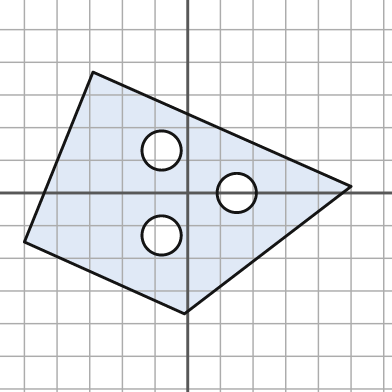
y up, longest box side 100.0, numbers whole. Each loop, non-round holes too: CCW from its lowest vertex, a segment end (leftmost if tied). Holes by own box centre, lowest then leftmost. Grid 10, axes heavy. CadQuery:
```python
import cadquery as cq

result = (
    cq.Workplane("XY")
    .moveTo(-1.0, -37.0)
    .lineTo(50.0, 2.0)
    .lineTo(-29.0, 37.0)
    .lineTo(-50.0, -15.0)
    .close()
    .moveTo(-8.0, -13.0)
    .circle(6.0)
    .moveTo(15.0, 0.0)
    .circle(6.0)
    .moveTo(-8.0, 13.0)
    .circle(6.0)
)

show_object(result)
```